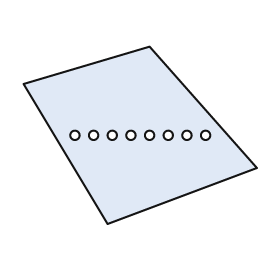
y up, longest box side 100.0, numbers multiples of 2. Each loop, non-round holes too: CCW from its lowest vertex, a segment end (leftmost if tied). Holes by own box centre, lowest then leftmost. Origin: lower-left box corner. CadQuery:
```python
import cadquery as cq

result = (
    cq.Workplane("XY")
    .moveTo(36.0, 0.0)
    .lineTo(100.0, 24.0)
    .lineTo(54.0, 76.0)
    .lineTo(0.0, 60.0)
    .close()
    .moveTo(22.0, 38.0)
    .circle(2.0)
    .moveTo(30.0, 38.0)
    .circle(2.0)
    .moveTo(38.0, 38.0)
    .circle(2.0)
    .moveTo(46.0, 38.0)
    .circle(2.0)
    .moveTo(54.0, 38.0)
    .circle(2.0)
    .moveTo(62.0, 38.0)
    .circle(2.0)
    .moveTo(70.0, 38.0)
    .circle(2.0)
    .moveTo(78.0, 38.0)
    .circle(2.0)
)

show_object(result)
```